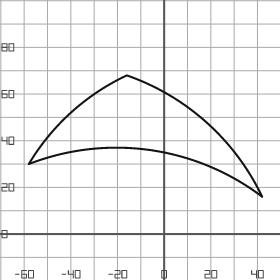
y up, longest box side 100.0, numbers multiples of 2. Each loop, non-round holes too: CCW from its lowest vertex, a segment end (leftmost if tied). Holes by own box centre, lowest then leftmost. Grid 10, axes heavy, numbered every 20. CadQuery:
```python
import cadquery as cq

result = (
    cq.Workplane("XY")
    .moveTo(42.0, 16.0)
    .threePointArc((18.0, 48.0), (-16.0, 68.0))
    .threePointArc((-40.0, 52.0), (-58.0, 30.0))
    .threePointArc((-6.0, 36.0), (42.0, 16.0))
    .close()
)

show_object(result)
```